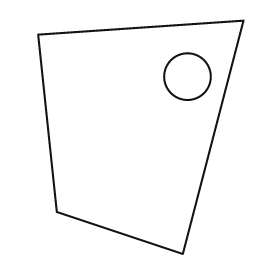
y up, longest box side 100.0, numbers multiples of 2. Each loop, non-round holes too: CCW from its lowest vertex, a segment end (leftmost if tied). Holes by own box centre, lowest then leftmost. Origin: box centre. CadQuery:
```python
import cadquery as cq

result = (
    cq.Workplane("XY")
    .moveTo(18.0, -50.0)
    .lineTo(44.0, 50.0)
    .lineTo(-44.0, 44.0)
    .lineTo(-36.0, -32.0)
    .close()
    .moveTo(20.0, 26.0)
    .circle(10.0)
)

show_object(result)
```